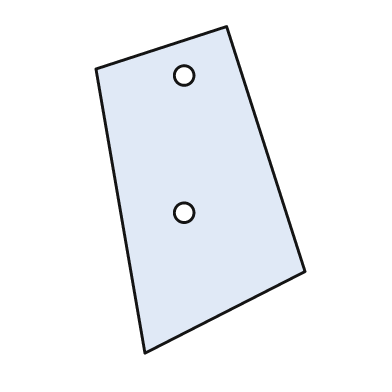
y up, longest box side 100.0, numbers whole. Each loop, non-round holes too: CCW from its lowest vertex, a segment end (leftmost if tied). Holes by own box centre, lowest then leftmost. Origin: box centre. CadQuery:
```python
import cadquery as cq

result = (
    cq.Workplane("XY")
    .moveTo(-17.0, -50.0)
    .lineTo(32.0, -25.0)
    .lineTo(8.0, 50.0)
    .lineTo(-32.0, 37.0)
    .close()
    .moveTo(-5.0, -7.0)
    .circle(3.0)
    .moveTo(-5.0, 35.0)
    .circle(3.0)
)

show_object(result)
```